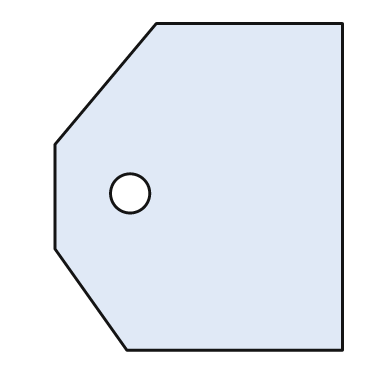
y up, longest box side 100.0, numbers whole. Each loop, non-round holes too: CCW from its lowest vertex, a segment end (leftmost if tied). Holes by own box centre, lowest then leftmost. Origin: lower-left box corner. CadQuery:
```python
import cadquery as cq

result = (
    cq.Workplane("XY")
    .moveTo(22.0, 0.0)
    .lineTo(88.0, 0.0)
    .lineTo(88.0, 100.0)
    .lineTo(31.0, 100.0)
    .lineTo(0.0, 63.0)
    .lineTo(0.0, 31.0)
    .close()
    .moveTo(23.0, 48.0)
    .circle(6.0)
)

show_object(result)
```